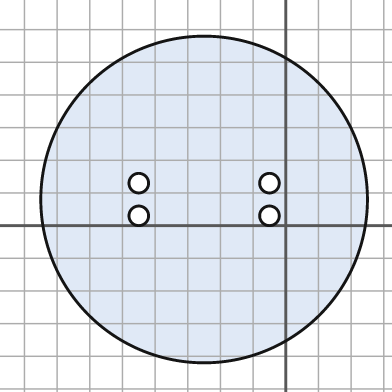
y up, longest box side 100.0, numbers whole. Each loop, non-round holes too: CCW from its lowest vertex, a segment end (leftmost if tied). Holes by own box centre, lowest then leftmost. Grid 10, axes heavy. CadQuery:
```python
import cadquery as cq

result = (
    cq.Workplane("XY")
    .moveTo(-25.0, 8.0)
    .circle(50.0)
    .moveTo(-45.0, 3.0)
    .circle(3.0)
    .moveTo(-5.0, 3.0)
    .circle(3.0)
    .moveTo(-45.0, 13.0)
    .circle(3.0)
    .moveTo(-5.0, 13.0)
    .circle(3.0)
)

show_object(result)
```